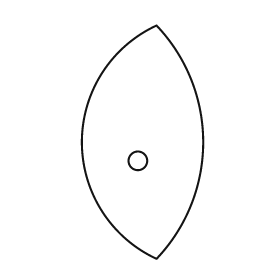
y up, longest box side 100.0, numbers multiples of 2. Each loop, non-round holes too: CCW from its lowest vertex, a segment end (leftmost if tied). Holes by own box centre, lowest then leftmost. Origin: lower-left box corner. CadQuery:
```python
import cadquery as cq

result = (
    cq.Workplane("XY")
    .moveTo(32.0, 0.0)
    .threePointArc((52.0, 50.0), (32.0, 100.0))
    .threePointArc((0.0, 50.0), (32.0, 0.0))
    .close()
    .moveTo(24.0, 42.0)
    .circle(4.0)
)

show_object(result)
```